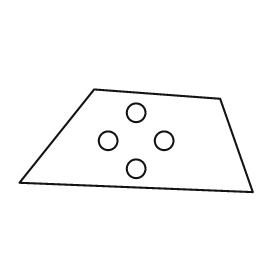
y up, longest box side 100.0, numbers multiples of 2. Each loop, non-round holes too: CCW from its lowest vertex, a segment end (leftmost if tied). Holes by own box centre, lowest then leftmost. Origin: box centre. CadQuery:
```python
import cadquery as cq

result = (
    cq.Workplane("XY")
    .moveTo(50.0, -22.0)
    .lineTo(36.0, 18.0)
    .lineTo(-18.0, 22.0)
    .lineTo(-50.0, -18.0)
    .close()
    .moveTo(0.0, -12.0)
    .circle(4.0)
    .moveTo(-12.0, 0.0)
    .circle(4.0)
    .moveTo(12.0, 0.0)
    .circle(4.0)
    .moveTo(0.0, 12.0)
    .circle(4.0)
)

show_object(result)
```